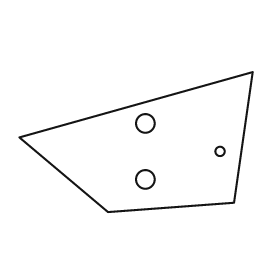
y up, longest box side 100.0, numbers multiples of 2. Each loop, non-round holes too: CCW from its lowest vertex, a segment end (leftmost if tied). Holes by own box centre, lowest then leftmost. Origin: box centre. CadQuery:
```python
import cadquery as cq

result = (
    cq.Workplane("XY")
    .moveTo(-12.0, -30.0)
    .lineTo(42.0, -26.0)
    .lineTo(50.0, 30.0)
    .lineTo(-50.0, 2.0)
    .close()
    .moveTo(4.0, -16.0)
    .circle(4.0)
    .moveTo(36.0, -4.0)
    .circle(2.0)
    .moveTo(4.0, 8.0)
    .circle(4.0)
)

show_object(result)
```